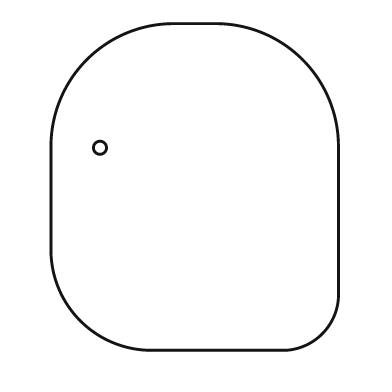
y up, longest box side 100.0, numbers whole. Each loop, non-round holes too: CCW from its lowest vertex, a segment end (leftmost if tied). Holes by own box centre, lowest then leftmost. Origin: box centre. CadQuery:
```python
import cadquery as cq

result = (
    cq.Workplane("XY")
    .moveTo(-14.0, -50.0)
    .lineTo(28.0, -50.0)
    .threePointArc((39.0, -45.0), (44.0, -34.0))
    .lineTo(44.0, 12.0)
    .threePointArc((33.0, 39.0), (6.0, 50.0))
    .lineTo(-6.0, 50.0)
    .threePointArc((-33.0, 39.0), (-44.0, 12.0))
    .lineTo(-44.0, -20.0)
    .threePointArc((-35.0, -41.0), (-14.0, -50.0))
    .close()
    .moveTo(-29.0, 12.0)
    .circle(2.0)
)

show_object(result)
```